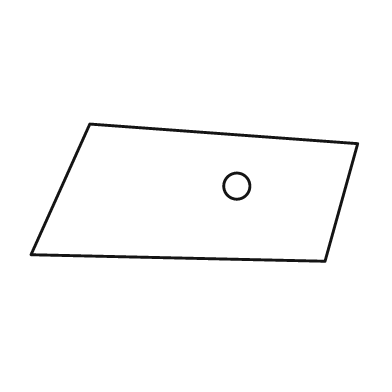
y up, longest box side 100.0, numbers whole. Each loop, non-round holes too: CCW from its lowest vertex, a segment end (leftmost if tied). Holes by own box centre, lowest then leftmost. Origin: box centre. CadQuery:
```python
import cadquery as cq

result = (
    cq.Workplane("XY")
    .moveTo(40.0, -21.0)
    .lineTo(50.0, 15.0)
    .lineTo(-32.0, 21.0)
    .lineTo(-50.0, -19.0)
    .close()
    .moveTo(13.0, 2.0)
    .circle(4.0)
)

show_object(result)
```